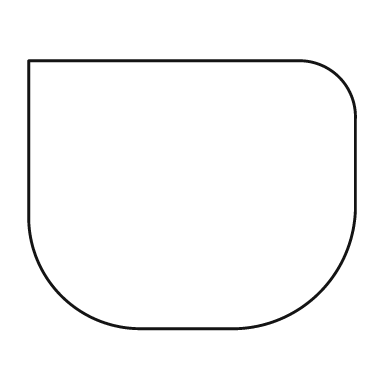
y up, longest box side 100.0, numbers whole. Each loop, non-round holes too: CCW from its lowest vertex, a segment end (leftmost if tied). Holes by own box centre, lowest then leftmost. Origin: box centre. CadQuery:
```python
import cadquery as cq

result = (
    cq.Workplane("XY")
    .moveTo(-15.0, -41.0)
    .lineTo(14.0, -41.0)
    .threePointArc((39.0, -30.0), (50.0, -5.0))
    .lineTo(50.0, 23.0)
    .threePointArc((45.0, 36.0), (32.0, 41.0))
    .lineTo(-50.0, 41.0)
    .lineTo(-50.0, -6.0)
    .threePointArc((-40.0, -31.0), (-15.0, -41.0))
    .close()
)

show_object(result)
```